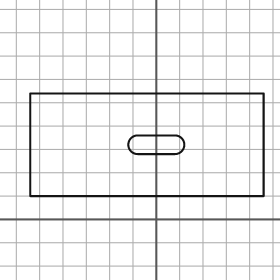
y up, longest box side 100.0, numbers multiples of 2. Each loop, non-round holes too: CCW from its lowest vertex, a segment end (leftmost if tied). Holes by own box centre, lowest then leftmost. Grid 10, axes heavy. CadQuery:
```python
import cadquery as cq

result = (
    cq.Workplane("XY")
    .moveTo(-54.0, 10.0)
    .lineTo(46.0, 10.0)
    .lineTo(46.0, 54.0)
    .lineTo(-54.0, 54.0)
    .close()
    .moveTo(-8.0, 28.0)
    .lineTo(8.0, 28.0)
    .threePointArc((12.0, 32.0), (8.0, 36.0))
    .lineTo(-8.0, 36.0)
    .threePointArc((-12.0, 32.0), (-8.0, 28.0))
    .close()
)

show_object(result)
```